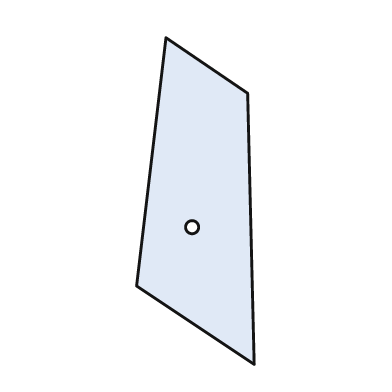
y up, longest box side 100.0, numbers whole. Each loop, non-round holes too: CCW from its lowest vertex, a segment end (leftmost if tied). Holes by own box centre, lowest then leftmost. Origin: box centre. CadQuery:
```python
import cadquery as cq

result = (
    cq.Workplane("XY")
    .moveTo(18.0, -50.0)
    .lineTo(16.0, 33.0)
    .lineTo(-9.0, 50.0)
    .lineTo(-18.0, -26.0)
    .close()
    .moveTo(-1.0, -8.0)
    .circle(2.0)
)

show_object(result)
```